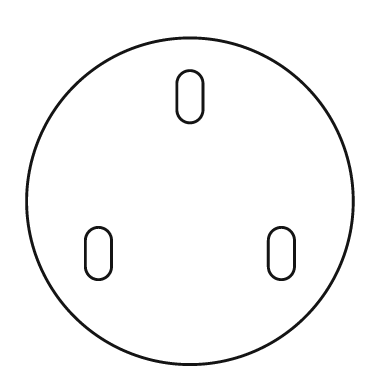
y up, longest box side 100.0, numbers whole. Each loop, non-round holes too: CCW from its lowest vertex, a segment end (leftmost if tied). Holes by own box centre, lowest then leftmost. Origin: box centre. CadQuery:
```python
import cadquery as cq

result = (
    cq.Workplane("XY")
    .moveTo(0.0, 0.0)
    .circle(50.0)
    .moveTo(-32.0, -20.0)
    .threePointArc((-28.0, -24.0), (-24.0, -20.0))
    .lineTo(-24.0, -12.0)
    .threePointArc((-28.0, -8.0), (-32.0, -12.0))
    .close()
    .moveTo(24.0, -20.0)
    .threePointArc((28.0, -24.0), (32.0, -20.0))
    .lineTo(32.0, -12.0)
    .threePointArc((28.0, -8.0), (24.0, -12.0))
    .close()
    .moveTo(-4.0, 28.0)
    .threePointArc((0.0, 24.0), (4.0, 28.0))
    .lineTo(4.0, 36.0)
    .threePointArc((0.0, 40.0), (-4.0, 36.0))
    .close()
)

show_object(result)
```